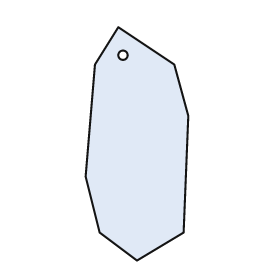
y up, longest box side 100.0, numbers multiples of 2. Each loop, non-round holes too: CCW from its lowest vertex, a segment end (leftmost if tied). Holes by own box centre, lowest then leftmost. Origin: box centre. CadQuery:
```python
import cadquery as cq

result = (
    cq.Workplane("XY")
    .moveTo(0.0, -50.0)
    .lineTo(20.0, -38.0)
    .lineTo(22.0, 12.0)
    .lineTo(16.0, 34.0)
    .lineTo(-8.0, 50.0)
    .lineTo(-18.0, 34.0)
    .lineTo(-22.0, -14.0)
    .lineTo(-16.0, -38.0)
    .close()
    .moveTo(-6.0, 38.0)
    .circle(2.0)
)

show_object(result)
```